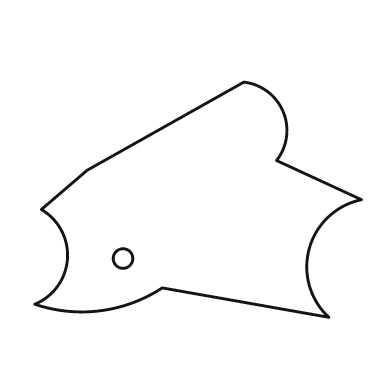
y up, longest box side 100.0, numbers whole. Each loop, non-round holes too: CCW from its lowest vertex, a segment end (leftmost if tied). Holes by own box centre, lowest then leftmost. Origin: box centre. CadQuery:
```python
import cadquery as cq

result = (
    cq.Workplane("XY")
    .moveTo(40.0, -36.0)
    .threePointArc((34.0, -15.0), (50.0, 0.0))
    .lineTo(24.0, 12.0)
    .threePointArc((26.0, 27.0), (14.0, 36.0))
    .lineTo(-34.0, 9.0)
    .lineTo(-48.0, -3.0)
    .threePointArc((-40.0, -18.0), (-50.0, -32.0))
    .threePointArc((-30.0, -34.0), (-11.0, -27.0))
    .close()
    .moveTo(-23.0, -18.0)
    .circle(3.0)
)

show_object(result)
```